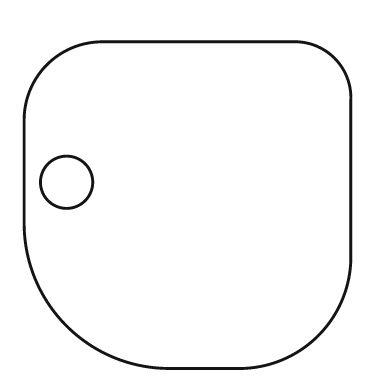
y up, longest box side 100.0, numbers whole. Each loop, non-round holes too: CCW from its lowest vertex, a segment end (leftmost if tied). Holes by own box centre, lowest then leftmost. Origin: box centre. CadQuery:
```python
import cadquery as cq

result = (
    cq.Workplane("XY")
    .moveTo(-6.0, -50.0)
    .lineTo(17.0, -50.0)
    .threePointArc((40.0, -40.0), (50.0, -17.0))
    .lineTo(50.0, 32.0)
    .threePointArc((45.0, 45.0), (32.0, 50.0))
    .lineTo(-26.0, 50.0)
    .threePointArc((-43.0, 43.0), (-50.0, 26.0))
    .lineTo(-50.0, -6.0)
    .threePointArc((-37.0, -37.0), (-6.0, -50.0))
    .close()
    .moveTo(-37.0, 7.0)
    .circle(8.0)
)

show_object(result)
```